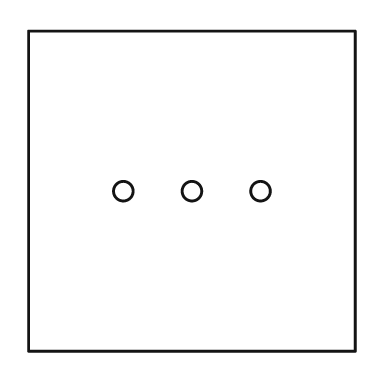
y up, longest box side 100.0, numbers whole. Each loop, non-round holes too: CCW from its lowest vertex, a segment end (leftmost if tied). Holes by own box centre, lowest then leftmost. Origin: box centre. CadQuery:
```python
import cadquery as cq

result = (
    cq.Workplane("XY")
    .moveTo(-50.0, -49.0)
    .lineTo(50.0, -49.0)
    .lineTo(50.0, 49.0)
    .lineTo(-50.0, 49.0)
    .close()
    .moveTo(-21.0, 0.0)
    .circle(3.0)
    .moveTo(0.0, 0.0)
    .circle(3.0)
    .moveTo(21.0, 0.0)
    .circle(3.0)
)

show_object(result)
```